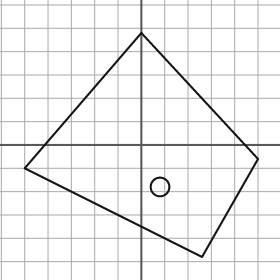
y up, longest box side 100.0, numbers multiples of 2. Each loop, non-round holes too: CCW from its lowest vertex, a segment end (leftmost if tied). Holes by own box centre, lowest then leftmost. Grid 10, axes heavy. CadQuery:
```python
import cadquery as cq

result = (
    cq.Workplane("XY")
    .moveTo(26.0, -48.0)
    .lineTo(50.0, -6.0)
    .lineTo(0.0, 48.0)
    .lineTo(-50.0, -10.0)
    .close()
    .moveTo(8.0, -18.0)
    .circle(4.0)
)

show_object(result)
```